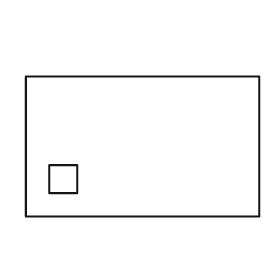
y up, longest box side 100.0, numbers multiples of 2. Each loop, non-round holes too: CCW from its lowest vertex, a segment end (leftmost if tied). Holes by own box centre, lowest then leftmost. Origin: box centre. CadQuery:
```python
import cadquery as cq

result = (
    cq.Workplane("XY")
    .moveTo(-50.0, -30.0)
    .lineTo(50.0, -30.0)
    .lineTo(50.0, 30.0)
    .lineTo(-50.0, 30.0)
    .close()
    .moveTo(-40.0, -20.0)
    .lineTo(-28.0, -20.0)
    .lineTo(-28.0, -8.0)
    .lineTo(-40.0, -8.0)
    .close()
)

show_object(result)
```